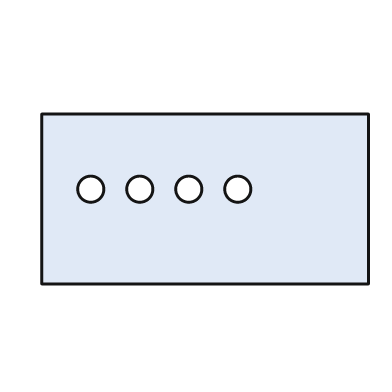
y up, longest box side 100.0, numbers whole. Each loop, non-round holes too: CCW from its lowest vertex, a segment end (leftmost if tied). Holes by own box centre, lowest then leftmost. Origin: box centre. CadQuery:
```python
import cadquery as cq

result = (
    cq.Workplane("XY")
    .moveTo(-50.0, -26.0)
    .lineTo(50.0, -26.0)
    .lineTo(50.0, 26.0)
    .lineTo(-50.0, 26.0)
    .close()
    .moveTo(-35.0, 3.0)
    .circle(4.0)
    .moveTo(-20.0, 3.0)
    .circle(4.0)
    .moveTo(-5.0, 3.0)
    .circle(4.0)
    .moveTo(10.0, 3.0)
    .circle(4.0)
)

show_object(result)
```